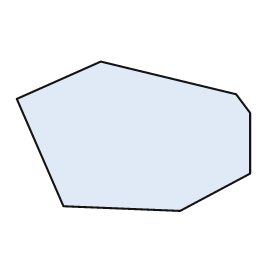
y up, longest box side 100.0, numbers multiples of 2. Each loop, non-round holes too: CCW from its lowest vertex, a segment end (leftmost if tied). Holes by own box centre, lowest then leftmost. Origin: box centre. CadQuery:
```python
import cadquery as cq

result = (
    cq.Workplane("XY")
    .moveTo(20.0, -32.0)
    .lineTo(50.0, -16.0)
    .lineTo(50.0, 10.0)
    .lineTo(44.0, 18.0)
    .lineTo(-14.0, 32.0)
    .lineTo(-50.0, 16.0)
    .lineTo(-30.0, -30.0)
    .close()
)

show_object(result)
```